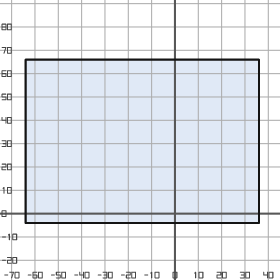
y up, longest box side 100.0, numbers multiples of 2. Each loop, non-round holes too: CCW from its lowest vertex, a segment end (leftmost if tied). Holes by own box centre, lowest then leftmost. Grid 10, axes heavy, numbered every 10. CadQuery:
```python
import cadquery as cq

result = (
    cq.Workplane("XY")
    .moveTo(-64.0, -4.0)
    .lineTo(36.0, -4.0)
    .lineTo(36.0, 66.0)
    .lineTo(-64.0, 66.0)
    .close()
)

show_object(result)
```